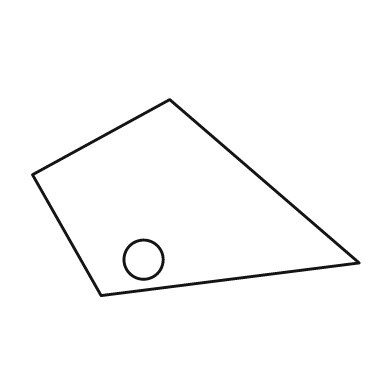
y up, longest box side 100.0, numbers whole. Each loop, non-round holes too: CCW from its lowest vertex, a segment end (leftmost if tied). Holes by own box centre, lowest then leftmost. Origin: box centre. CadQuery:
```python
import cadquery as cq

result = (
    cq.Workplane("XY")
    .moveTo(-29.0, -30.0)
    .lineTo(50.0, -20.0)
    .lineTo(-8.0, 30.0)
    .lineTo(-50.0, 7.0)
    .close()
    .moveTo(-16.0, -19.0)
    .circle(6.0)
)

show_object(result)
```